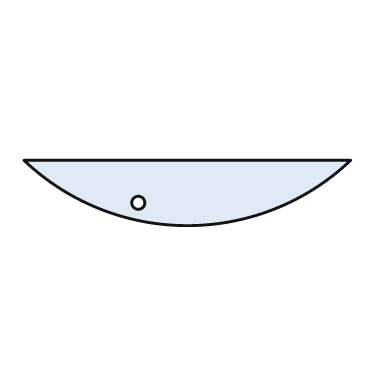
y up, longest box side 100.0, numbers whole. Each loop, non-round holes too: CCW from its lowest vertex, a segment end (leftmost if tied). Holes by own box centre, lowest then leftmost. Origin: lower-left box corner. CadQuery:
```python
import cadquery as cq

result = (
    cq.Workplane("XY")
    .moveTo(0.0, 20.0)
    .threePointArc((50.0, 0.0), (100.0, 20.0))
    .close()
    .moveTo(35.0, 7.0)
    .circle(2.0)
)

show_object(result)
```